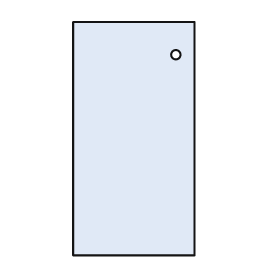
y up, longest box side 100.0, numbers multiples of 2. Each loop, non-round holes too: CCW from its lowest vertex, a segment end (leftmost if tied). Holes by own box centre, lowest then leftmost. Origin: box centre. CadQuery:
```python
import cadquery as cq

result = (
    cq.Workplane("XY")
    .moveTo(-26.0, -50.0)
    .lineTo(26.0, -50.0)
    .lineTo(26.0, 50.0)
    .lineTo(-26.0, 50.0)
    .close()
    .moveTo(18.0, 36.0)
    .circle(2.0)
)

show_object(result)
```